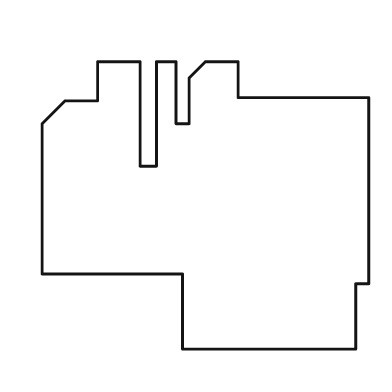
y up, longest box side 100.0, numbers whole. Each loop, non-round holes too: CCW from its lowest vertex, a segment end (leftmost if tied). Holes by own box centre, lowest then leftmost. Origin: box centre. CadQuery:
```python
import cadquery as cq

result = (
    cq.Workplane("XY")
    .moveTo(-7.0, -44.0)
    .lineTo(46.0, -44.0)
    .lineTo(46.0, -24.0)
    .lineTo(50.0, -24.0)
    .lineTo(50.0, 33.0)
    .lineTo(10.0, 33.0)
    .lineTo(10.0, 44.0)
    .lineTo(0.0, 44.0)
    .lineTo(-5.0, 39.0)
    .lineTo(-5.0, 25.0)
    .lineTo(-9.0, 25.0)
    .lineTo(-9.0, 44.0)
    .lineTo(-15.0, 44.0)
    .lineTo(-15.0, 12.0)
    .lineTo(-20.0, 12.0)
    .lineTo(-20.0, 44.0)
    .lineTo(-33.0, 44.0)
    .lineTo(-33.0, 32.0)
    .lineTo(-43.0, 32.0)
    .lineTo(-50.0, 25.0)
    .lineTo(-50.0, -21.0)
    .lineTo(-7.0, -21.0)
    .close()
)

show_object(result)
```